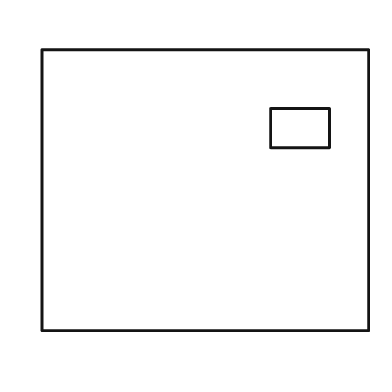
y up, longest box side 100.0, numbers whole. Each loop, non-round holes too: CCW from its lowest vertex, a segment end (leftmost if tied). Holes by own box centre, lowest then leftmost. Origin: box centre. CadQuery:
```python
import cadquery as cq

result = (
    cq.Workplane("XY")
    .moveTo(-50.0, -43.0)
    .lineTo(50.0, -43.0)
    .lineTo(50.0, 43.0)
    .lineTo(-50.0, 43.0)
    .close()
    .moveTo(20.0, 13.0)
    .lineTo(38.0, 13.0)
    .lineTo(38.0, 25.0)
    .lineTo(20.0, 25.0)
    .close()
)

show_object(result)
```